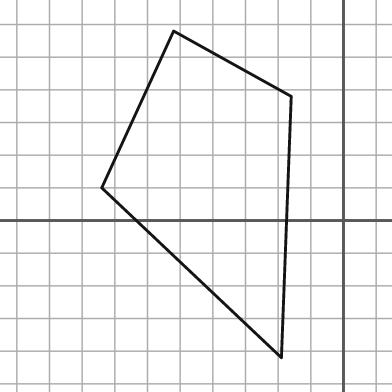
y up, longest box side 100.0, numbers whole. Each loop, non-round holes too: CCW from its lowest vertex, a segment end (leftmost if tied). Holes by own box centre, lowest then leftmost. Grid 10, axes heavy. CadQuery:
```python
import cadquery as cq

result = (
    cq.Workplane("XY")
    .moveTo(-19.0, -42.0)
    .lineTo(-16.0, 38.0)
    .lineTo(-52.0, 58.0)
    .lineTo(-74.0, 10.0)
    .close()
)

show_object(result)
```